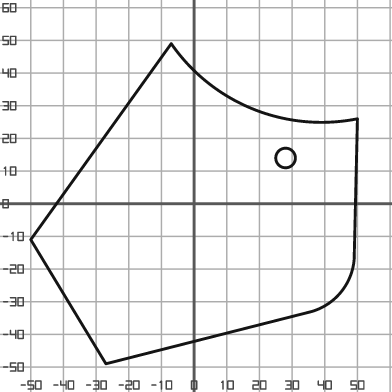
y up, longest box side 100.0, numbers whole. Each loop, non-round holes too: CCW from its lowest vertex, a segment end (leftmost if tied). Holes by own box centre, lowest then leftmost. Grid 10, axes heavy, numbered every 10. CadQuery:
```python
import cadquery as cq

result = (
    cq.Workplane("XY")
    .moveTo(-27.0, -49.0)
    .lineTo(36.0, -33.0)
    .threePointArc((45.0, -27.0), (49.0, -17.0))
    .lineTo(50.0, 26.0)
    .threePointArc((18.0, 29.0), (-7.0, 49.0))
    .lineTo(-50.0, -11.0)
    .close()
    .moveTo(28.0, 14.0)
    .circle(3.0)
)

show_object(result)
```